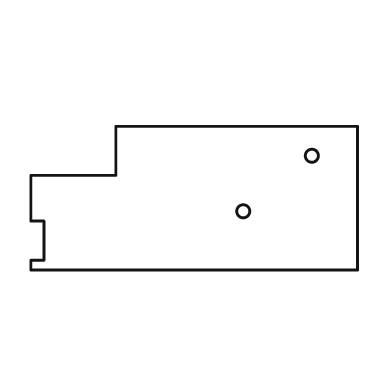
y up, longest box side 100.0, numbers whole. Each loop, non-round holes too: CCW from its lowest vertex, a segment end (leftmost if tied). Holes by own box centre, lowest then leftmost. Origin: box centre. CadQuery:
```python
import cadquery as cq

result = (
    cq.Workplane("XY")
    .moveTo(-50.0, -22.0)
    .lineTo(50.0, -22.0)
    .lineTo(50.0, 22.0)
    .lineTo(-24.0, 22.0)
    .lineTo(-24.0, 7.0)
    .lineTo(-50.0, 7.0)
    .lineTo(-50.0, -7.0)
    .lineTo(-46.0, -7.0)
    .lineTo(-46.0, -19.0)
    .lineTo(-50.0, -19.0)
    .close()
    .moveTo(15.0, -4.0)
    .circle(2.0)
    .moveTo(36.0, 13.0)
    .circle(2.0)
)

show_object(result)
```